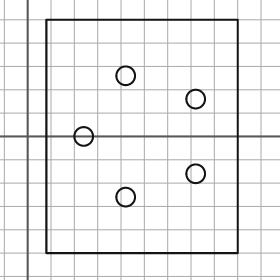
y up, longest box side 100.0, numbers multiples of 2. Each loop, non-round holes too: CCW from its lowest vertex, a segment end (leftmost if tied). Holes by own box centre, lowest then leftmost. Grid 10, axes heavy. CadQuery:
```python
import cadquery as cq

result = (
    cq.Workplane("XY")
    .moveTo(8.0, -50.0)
    .lineTo(90.0, -50.0)
    .lineTo(90.0, 50.0)
    .lineTo(8.0, 50.0)
    .close()
    .moveTo(42.0, -26.0)
    .circle(4.0)
    .moveTo(72.0, -16.0)
    .circle(4.0)
    .moveTo(24.0, 0.0)
    .circle(4.0)
    .moveTo(72.0, 16.0)
    .circle(4.0)
    .moveTo(42.0, 26.0)
    .circle(4.0)
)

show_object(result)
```